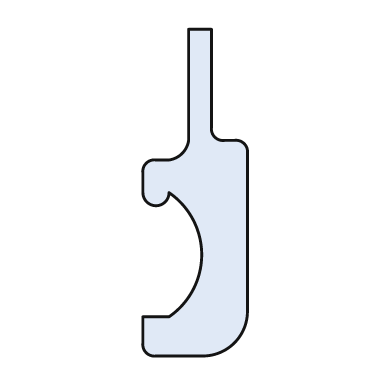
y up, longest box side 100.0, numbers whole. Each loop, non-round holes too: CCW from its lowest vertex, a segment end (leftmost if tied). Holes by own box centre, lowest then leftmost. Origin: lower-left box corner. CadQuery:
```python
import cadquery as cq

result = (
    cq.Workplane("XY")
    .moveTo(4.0, 0.0)
    .lineTo(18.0, 0.0)
    .threePointArc((28.0, 4.0), (32.0, 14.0))
    .lineTo(32.0, 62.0)
    .threePointArc((31.0, 65.0), (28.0, 66.0))
    .lineTo(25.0, 66.0)
    .threePointArc((22.0, 67.0), (21.0, 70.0))
    .lineTo(21.0, 100.0)
    .lineTo(14.0, 100.0)
    .lineTo(14.0, 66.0)
    .threePointArc((12.0, 62.0), (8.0, 60.0))
    .lineTo(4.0, 60.0)
    .threePointArc((1.0, 59.0), (0.0, 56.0))
    .lineTo(0.0, 50.0)
    .threePointArc((4.0, 46.0), (8.0, 50.0))
    .threePointArc((18.0, 31.0), (8.0, 12.0))
    .lineTo(0.0, 12.0)
    .lineTo(0.0, 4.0)
    .threePointArc((1.0, 1.0), (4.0, 0.0))
    .close()
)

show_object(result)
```